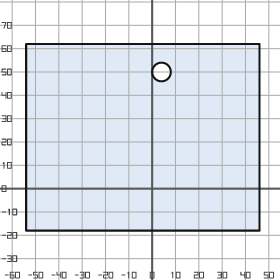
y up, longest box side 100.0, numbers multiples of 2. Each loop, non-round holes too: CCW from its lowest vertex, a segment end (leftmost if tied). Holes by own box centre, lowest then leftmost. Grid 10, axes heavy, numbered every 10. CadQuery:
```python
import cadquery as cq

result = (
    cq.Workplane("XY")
    .moveTo(-54.0, -18.0)
    .lineTo(46.0, -18.0)
    .lineTo(46.0, 62.0)
    .lineTo(-54.0, 62.0)
    .close()
    .moveTo(4.0, 50.0)
    .circle(4.0)
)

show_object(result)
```